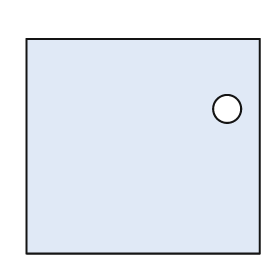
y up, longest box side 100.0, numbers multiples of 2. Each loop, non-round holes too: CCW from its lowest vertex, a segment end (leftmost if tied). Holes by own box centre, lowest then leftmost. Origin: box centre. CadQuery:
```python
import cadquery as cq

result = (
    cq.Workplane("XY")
    .moveTo(-50.0, -46.0)
    .lineTo(50.0, -46.0)
    .lineTo(50.0, 46.0)
    .lineTo(-50.0, 46.0)
    .close()
    .moveTo(36.0, 16.0)
    .circle(6.0)
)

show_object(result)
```